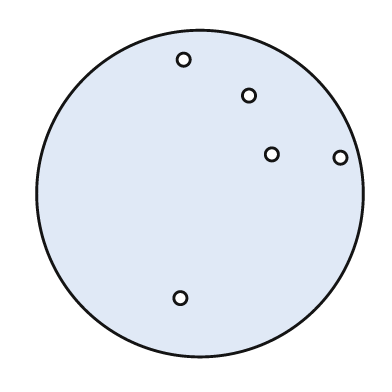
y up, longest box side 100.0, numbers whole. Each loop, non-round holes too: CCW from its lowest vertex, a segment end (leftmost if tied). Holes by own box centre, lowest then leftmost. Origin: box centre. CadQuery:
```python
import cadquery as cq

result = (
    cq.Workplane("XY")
    .moveTo(0.0, 0.0)
    .circle(50.0)
    .moveTo(-6.0, -32.0)
    .circle(2.0)
    .moveTo(43.0, 11.0)
    .circle(2.0)
    .moveTo(22.0, 12.0)
    .circle(2.0)
    .moveTo(15.0, 30.0)
    .circle(2.0)
    .moveTo(-5.0, 41.0)
    .circle(2.0)
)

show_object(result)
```